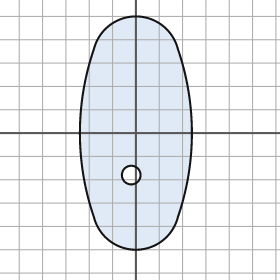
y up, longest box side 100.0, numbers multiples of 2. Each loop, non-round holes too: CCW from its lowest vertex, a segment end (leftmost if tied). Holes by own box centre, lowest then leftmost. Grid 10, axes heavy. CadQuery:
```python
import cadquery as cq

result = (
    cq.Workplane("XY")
    .moveTo(-18.0, -36.0)
    .threePointArc((0.0, -50.0), (18.0, -36.0))
    .threePointArc((24.0, 0.0), (18.0, 36.0))
    .threePointArc((0.0, 50.0), (-18.0, 36.0))
    .threePointArc((-24.0, 0.0), (-18.0, -36.0))
    .close()
    .moveTo(-2.0, -18.0)
    .circle(4.0)
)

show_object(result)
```